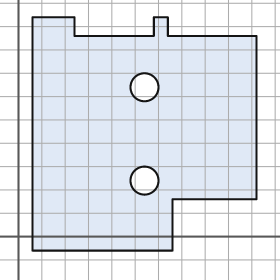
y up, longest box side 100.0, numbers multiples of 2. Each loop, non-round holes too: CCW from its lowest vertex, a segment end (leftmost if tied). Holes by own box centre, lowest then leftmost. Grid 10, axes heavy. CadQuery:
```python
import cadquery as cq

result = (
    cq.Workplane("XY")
    .moveTo(6.0, -6.0)
    .lineTo(66.0, -6.0)
    .lineTo(66.0, 16.0)
    .lineTo(102.0, 16.0)
    .lineTo(102.0, 86.0)
    .lineTo(64.0, 86.0)
    .lineTo(64.0, 94.0)
    .lineTo(58.0, 94.0)
    .lineTo(58.0, 86.0)
    .lineTo(24.0, 86.0)
    .lineTo(24.0, 94.0)
    .lineTo(6.0, 94.0)
    .close()
    .moveTo(54.0, 24.0)
    .circle(6.0)
    .moveTo(54.0, 64.0)
    .circle(6.0)
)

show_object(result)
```